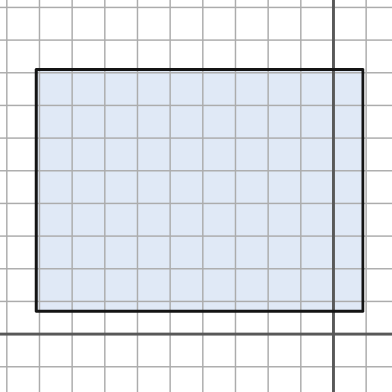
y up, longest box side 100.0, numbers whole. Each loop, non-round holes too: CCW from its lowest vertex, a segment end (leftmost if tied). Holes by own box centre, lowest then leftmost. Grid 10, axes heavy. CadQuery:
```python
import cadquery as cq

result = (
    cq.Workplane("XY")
    .moveTo(-91.0, 7.0)
    .lineTo(9.0, 7.0)
    .lineTo(9.0, 81.0)
    .lineTo(-91.0, 81.0)
    .close()
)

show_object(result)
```